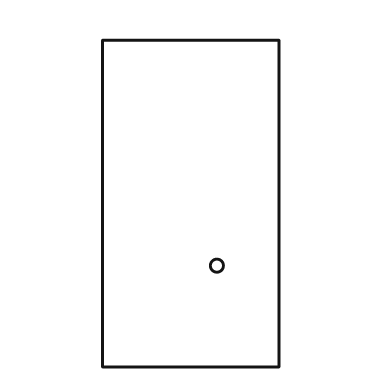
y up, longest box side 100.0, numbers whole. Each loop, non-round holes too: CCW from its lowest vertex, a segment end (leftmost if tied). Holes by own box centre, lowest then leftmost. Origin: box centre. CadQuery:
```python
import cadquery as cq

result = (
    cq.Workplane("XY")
    .moveTo(-27.0, -50.0)
    .lineTo(27.0, -50.0)
    .lineTo(27.0, 50.0)
    .lineTo(-27.0, 50.0)
    .close()
    .moveTo(8.0, -19.0)
    .circle(2.0)
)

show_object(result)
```